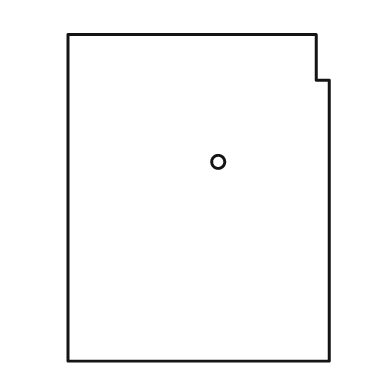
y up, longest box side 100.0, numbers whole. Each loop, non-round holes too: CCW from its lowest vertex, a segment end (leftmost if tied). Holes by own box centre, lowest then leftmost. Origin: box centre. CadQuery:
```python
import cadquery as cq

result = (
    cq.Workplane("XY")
    .moveTo(-40.0, -50.0)
    .lineTo(40.0, -50.0)
    .lineTo(40.0, 36.0)
    .lineTo(36.0, 36.0)
    .lineTo(36.0, 50.0)
    .lineTo(-40.0, 50.0)
    .close()
    .moveTo(6.0, 11.0)
    .circle(2.0)
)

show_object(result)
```